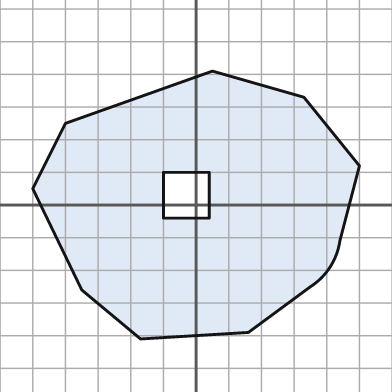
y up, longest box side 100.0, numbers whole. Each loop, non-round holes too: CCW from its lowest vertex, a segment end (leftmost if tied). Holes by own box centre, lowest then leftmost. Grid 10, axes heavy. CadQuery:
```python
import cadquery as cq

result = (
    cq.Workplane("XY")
    .moveTo(-17.0, -41.0)
    .lineTo(16.0, -39.0)
    .lineTo(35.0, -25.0)
    .threePointArc((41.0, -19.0), (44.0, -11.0))
    .lineTo(50.0, 12.0)
    .lineTo(33.0, 33.0)
    .lineTo(5.0, 41.0)
    .lineTo(-40.0, 25.0)
    .lineTo(-50.0, 5.0)
    .lineTo(-35.0, -26.0)
    .close()
    .moveTo(-10.0, -4.0)
    .lineTo(4.0, -4.0)
    .lineTo(4.0, 10.0)
    .lineTo(-10.0, 10.0)
    .close()
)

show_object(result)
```